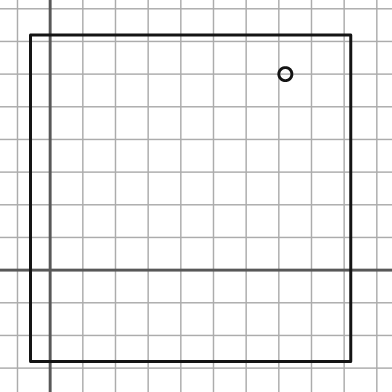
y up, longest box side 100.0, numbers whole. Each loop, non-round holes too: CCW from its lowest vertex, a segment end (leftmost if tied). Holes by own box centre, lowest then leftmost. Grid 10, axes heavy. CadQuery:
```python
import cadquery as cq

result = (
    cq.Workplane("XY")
    .moveTo(-6.0, -28.0)
    .lineTo(92.0, -28.0)
    .lineTo(92.0, 72.0)
    .lineTo(-6.0, 72.0)
    .close()
    .moveTo(72.0, 60.0)
    .circle(2.0)
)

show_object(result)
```